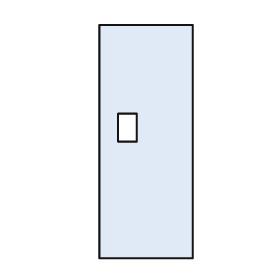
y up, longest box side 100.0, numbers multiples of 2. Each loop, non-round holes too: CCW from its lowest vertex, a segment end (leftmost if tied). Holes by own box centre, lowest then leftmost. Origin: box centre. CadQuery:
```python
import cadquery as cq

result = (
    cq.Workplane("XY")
    .moveTo(-20.0, -50.0)
    .lineTo(20.0, -50.0)
    .lineTo(20.0, 50.0)
    .lineTo(-20.0, 50.0)
    .close()
    .moveTo(-12.0, 0.0)
    .lineTo(-4.0, 0.0)
    .lineTo(-4.0, 12.0)
    .lineTo(-12.0, 12.0)
    .close()
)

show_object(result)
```